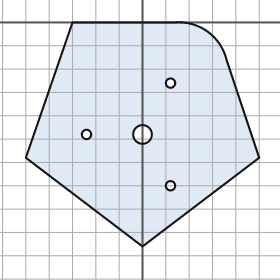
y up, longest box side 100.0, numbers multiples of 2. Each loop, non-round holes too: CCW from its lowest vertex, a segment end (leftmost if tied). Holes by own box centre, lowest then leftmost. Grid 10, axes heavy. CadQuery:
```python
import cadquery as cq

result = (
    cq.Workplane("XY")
    .moveTo(0.0, -96.0)
    .lineTo(50.0, -58.0)
    .lineTo(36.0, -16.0)
    .threePointArc((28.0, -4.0), (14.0, 0.0))
    .lineTo(-30.0, 0.0)
    .lineTo(-50.0, -58.0)
    .close()
    .moveTo(12.0, -70.0)
    .circle(2.0)
    .moveTo(-24.0, -48.0)
    .circle(2.0)
    .moveTo(0.0, -48.0)
    .circle(4.0)
    .moveTo(12.0, -26.0)
    .circle(2.0)
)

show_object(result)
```